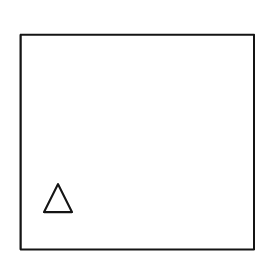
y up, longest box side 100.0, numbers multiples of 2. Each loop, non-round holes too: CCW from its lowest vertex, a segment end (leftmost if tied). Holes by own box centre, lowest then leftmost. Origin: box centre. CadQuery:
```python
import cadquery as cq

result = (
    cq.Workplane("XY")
    .moveTo(-50.0, -46.0)
    .lineTo(50.0, -46.0)
    .lineTo(50.0, 46.0)
    .lineTo(-50.0, 46.0)
    .close()
    .moveTo(-40.0, -30.0)
    .lineTo(-28.0, -30.0)
    .lineTo(-34.0, -18.0)
    .close()
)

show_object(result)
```